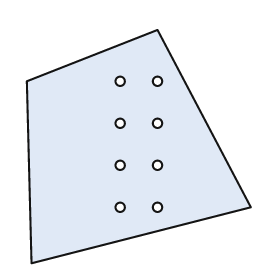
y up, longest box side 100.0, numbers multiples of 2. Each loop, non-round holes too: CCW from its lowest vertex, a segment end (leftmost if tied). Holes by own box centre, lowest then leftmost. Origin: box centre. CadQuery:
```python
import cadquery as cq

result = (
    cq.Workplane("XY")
    .moveTo(-46.0, -50.0)
    .lineTo(48.0, -26.0)
    .lineTo(8.0, 50.0)
    .lineTo(-48.0, 28.0)
    .close()
    .moveTo(-8.0, -26.0)
    .circle(2.0)
    .moveTo(8.0, -26.0)
    .circle(2.0)
    .moveTo(-8.0, -8.0)
    .circle(2.0)
    .moveTo(8.0, -8.0)
    .circle(2.0)
    .moveTo(-8.0, 10.0)
    .circle(2.0)
    .moveTo(8.0, 10.0)
    .circle(2.0)
    .moveTo(-8.0, 28.0)
    .circle(2.0)
    .moveTo(8.0, 28.0)
    .circle(2.0)
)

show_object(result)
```